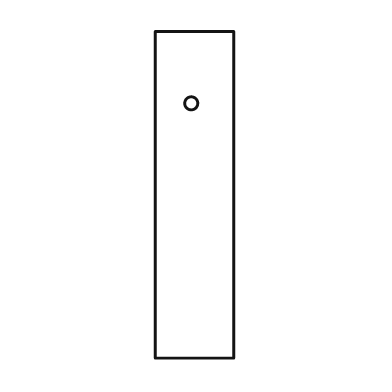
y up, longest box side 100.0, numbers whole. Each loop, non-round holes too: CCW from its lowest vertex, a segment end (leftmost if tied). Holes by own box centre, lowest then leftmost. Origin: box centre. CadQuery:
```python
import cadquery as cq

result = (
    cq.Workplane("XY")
    .moveTo(-12.0, -50.0)
    .lineTo(12.0, -50.0)
    .lineTo(12.0, 50.0)
    .lineTo(-12.0, 50.0)
    .close()
    .moveTo(-1.0, 28.0)
    .circle(2.0)
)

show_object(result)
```